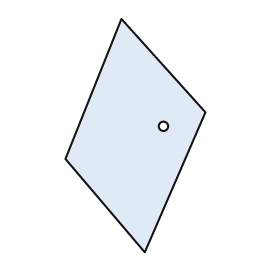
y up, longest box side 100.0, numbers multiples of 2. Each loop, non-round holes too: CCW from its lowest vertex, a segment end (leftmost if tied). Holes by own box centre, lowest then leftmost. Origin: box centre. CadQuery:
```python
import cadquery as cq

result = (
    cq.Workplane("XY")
    .moveTo(4.0, -50.0)
    .lineTo(30.0, 10.0)
    .lineTo(-6.0, 50.0)
    .lineTo(-30.0, -10.0)
    .close()
    .moveTo(12.0, 4.0)
    .circle(2.0)
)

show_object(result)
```